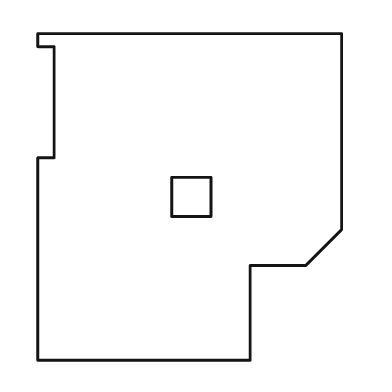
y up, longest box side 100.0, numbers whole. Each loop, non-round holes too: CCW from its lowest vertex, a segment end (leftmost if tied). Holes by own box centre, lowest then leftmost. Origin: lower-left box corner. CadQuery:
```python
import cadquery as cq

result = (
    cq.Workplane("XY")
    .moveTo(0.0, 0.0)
    .lineTo(65.0, 0.0)
    .lineTo(65.0, 29.0)
    .lineTo(82.0, 29.0)
    .lineTo(93.0, 40.0)
    .lineTo(93.0, 100.0)
    .lineTo(0.0, 100.0)
    .lineTo(0.0, 96.0)
    .lineTo(5.0, 96.0)
    .lineTo(5.0, 62.0)
    .lineTo(0.0, 62.0)
    .close()
    .moveTo(41.0, 44.0)
    .lineTo(53.0, 44.0)
    .lineTo(53.0, 56.0)
    .lineTo(41.0, 56.0)
    .close()
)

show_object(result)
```